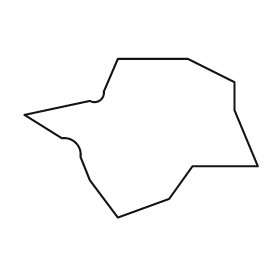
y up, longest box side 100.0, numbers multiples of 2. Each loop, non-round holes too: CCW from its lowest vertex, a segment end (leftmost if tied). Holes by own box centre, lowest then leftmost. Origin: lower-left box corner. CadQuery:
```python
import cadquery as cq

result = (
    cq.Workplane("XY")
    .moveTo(40.0, 0.0)
    .lineTo(62.0, 8.0)
    .lineTo(72.0, 22.0)
    .lineTo(100.0, 22.0)
    .lineTo(90.0, 46.0)
    .lineTo(90.0, 58.0)
    .lineTo(70.0, 68.0)
    .lineTo(40.0, 68.0)
    .lineTo(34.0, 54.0)
    .threePointArc((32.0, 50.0), (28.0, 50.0))
    .lineTo(0.0, 44.0)
    .lineTo(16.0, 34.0)
    .threePointArc((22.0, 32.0), (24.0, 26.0))
    .lineTo(28.0, 16.0)
    .close()
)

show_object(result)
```